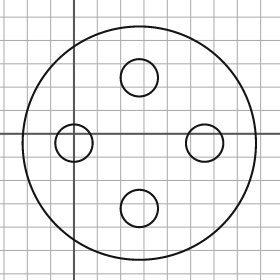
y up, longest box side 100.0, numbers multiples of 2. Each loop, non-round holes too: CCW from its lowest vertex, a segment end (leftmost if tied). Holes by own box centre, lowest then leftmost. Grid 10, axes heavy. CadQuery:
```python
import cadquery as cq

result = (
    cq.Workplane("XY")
    .moveTo(28.0, -4.0)
    .circle(50.0)
    .moveTo(28.0, -32.0)
    .circle(8.0)
    .moveTo(0.0, -4.0)
    .circle(8.0)
    .moveTo(56.0, -4.0)
    .circle(8.0)
    .moveTo(28.0, 24.0)
    .circle(8.0)
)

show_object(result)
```